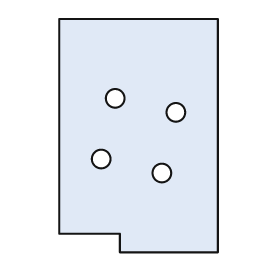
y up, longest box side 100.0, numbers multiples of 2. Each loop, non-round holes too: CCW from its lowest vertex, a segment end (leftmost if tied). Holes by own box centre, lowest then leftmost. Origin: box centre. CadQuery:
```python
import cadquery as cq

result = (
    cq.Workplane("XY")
    .moveTo(-8.0, -50.0)
    .lineTo(34.0, -50.0)
    .lineTo(34.0, 50.0)
    .lineTo(-34.0, 50.0)
    .lineTo(-34.0, -42.0)
    .lineTo(-8.0, -42.0)
    .close()
    .moveTo(10.0, -16.0)
    .circle(4.0)
    .moveTo(-16.0, -10.0)
    .circle(4.0)
    .moveTo(16.0, 10.0)
    .circle(4.0)
    .moveTo(-10.0, 16.0)
    .circle(4.0)
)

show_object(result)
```